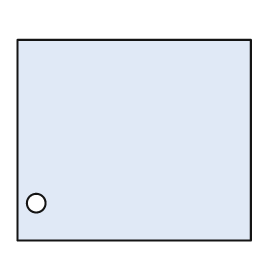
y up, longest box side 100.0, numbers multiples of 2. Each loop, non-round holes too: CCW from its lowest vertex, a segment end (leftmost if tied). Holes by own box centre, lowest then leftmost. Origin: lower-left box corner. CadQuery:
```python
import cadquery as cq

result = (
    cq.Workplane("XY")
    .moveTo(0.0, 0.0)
    .lineTo(100.0, 0.0)
    .lineTo(100.0, 86.0)
    .lineTo(0.0, 86.0)
    .close()
    .moveTo(8.0, 16.0)
    .circle(4.0)
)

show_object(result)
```